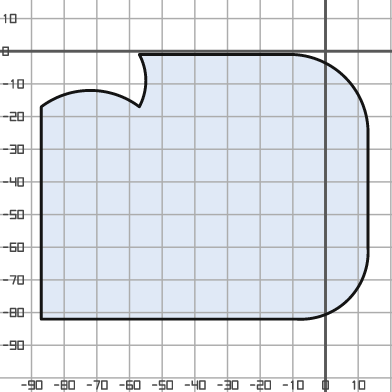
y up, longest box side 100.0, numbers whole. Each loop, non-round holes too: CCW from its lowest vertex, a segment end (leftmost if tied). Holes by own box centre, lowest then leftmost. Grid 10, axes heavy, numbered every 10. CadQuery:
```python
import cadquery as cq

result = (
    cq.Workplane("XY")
    .moveTo(-87.0, -82.0)
    .lineTo(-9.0, -82.0)
    .threePointArc((7.0, -76.0), (13.0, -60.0))
    .lineTo(13.0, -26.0)
    .threePointArc((6.0, -8.0), (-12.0, -1.0))
    .lineTo(-57.0, -1.0)
    .threePointArc((-55.0, -9.0), (-57.0, -17.0))
    .threePointArc((-72.0, -12.0), (-87.0, -17.0))
    .close()
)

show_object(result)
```